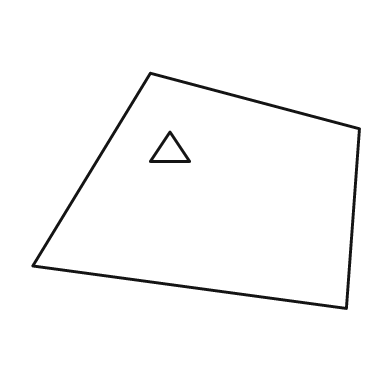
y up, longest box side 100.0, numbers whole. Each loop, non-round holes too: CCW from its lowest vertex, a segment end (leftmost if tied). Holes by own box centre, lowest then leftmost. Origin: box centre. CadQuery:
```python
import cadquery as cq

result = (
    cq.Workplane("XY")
    .moveTo(46.0, -36.0)
    .lineTo(50.0, 19.0)
    .lineTo(-14.0, 36.0)
    .lineTo(-50.0, -23.0)
    .close()
    .moveTo(-14.0, 9.0)
    .lineTo(-2.0, 9.0)
    .lineTo(-8.0, 18.0)
    .close()
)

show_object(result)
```